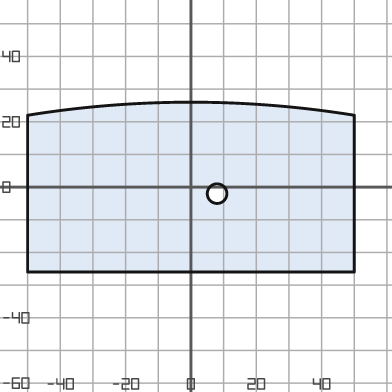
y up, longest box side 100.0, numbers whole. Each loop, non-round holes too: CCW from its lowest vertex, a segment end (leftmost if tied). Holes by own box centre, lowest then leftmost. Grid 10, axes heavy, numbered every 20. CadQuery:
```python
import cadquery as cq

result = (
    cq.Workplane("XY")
    .moveTo(-50.0, -26.0)
    .lineTo(50.0, -26.0)
    .lineTo(50.0, 22.0)
    .threePointArc((0.0, 26.0), (-50.0, 22.0))
    .close()
    .moveTo(8.0, -2.0)
    .circle(3.0)
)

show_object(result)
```